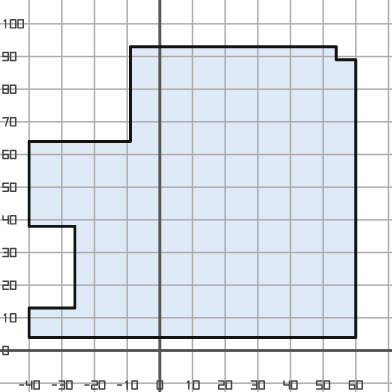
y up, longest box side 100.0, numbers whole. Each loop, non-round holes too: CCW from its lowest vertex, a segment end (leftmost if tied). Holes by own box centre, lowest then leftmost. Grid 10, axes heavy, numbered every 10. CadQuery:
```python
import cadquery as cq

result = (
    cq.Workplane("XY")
    .moveTo(-40.0, 4.0)
    .lineTo(60.0, 4.0)
    .lineTo(60.0, 89.0)
    .lineTo(54.0, 89.0)
    .lineTo(54.0, 93.0)
    .lineTo(-9.0, 93.0)
    .lineTo(-9.0, 64.0)
    .lineTo(-40.0, 64.0)
    .lineTo(-40.0, 38.0)
    .lineTo(-26.0, 38.0)
    .lineTo(-26.0, 13.0)
    .lineTo(-40.0, 13.0)
    .close()
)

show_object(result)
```